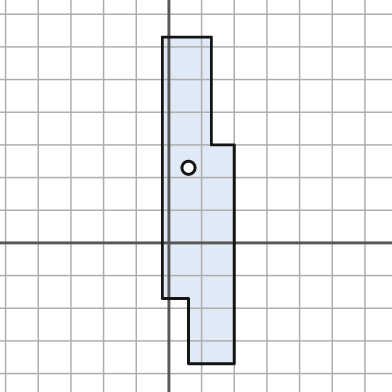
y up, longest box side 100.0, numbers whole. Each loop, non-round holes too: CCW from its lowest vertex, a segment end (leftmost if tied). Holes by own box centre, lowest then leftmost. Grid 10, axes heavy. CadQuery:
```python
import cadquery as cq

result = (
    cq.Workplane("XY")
    .moveTo(6.0, -37.0)
    .lineTo(20.0, -37.0)
    .lineTo(20.0, 30.0)
    .lineTo(13.0, 30.0)
    .lineTo(13.0, 63.0)
    .lineTo(-2.0, 63.0)
    .lineTo(-2.0, -17.0)
    .lineTo(6.0, -17.0)
    .close()
    .moveTo(6.0, 23.0)
    .circle(2.0)
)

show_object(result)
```